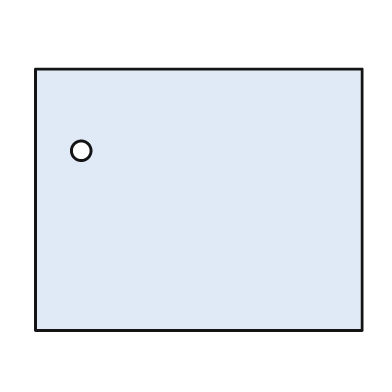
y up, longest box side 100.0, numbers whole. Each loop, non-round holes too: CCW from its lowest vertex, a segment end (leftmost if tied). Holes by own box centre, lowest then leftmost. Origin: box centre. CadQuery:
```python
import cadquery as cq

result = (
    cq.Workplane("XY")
    .moveTo(-50.0, -40.0)
    .lineTo(50.0, -40.0)
    .lineTo(50.0, 40.0)
    .lineTo(-50.0, 40.0)
    .close()
    .moveTo(-36.0, 15.0)
    .circle(3.0)
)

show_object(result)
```